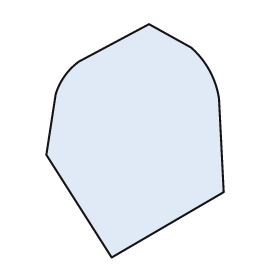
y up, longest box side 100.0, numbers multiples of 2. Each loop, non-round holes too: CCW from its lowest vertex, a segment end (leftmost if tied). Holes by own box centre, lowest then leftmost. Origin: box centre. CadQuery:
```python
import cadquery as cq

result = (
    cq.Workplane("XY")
    .moveTo(-10.0, -50.0)
    .lineTo(38.0, -22.0)
    .lineTo(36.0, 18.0)
    .threePointArc((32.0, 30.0), (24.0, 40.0))
    .lineTo(6.0, 50.0)
    .lineTo(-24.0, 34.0)
    .threePointArc((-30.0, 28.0), (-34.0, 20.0))
    .lineTo(-38.0, -6.0)
    .close()
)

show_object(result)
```